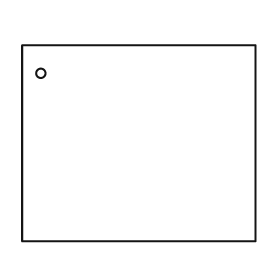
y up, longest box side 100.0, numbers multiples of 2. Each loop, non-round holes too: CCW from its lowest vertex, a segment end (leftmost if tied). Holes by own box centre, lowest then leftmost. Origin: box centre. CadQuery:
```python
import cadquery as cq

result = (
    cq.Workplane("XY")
    .moveTo(-50.0, -42.0)
    .lineTo(50.0, -42.0)
    .lineTo(50.0, 42.0)
    .lineTo(-50.0, 42.0)
    .close()
    .moveTo(-42.0, 30.0)
    .circle(2.0)
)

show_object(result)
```